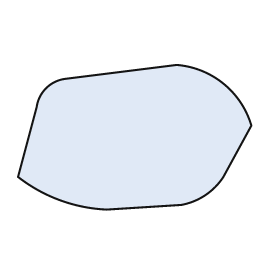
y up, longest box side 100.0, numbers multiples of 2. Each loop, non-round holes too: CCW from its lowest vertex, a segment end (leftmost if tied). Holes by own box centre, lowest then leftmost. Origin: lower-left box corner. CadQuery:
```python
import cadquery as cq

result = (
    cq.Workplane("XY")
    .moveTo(38.0, 0.0)
    .lineTo(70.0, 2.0)
    .threePointArc((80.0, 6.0), (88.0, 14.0))
    .lineTo(100.0, 36.0)
    .threePointArc((88.0, 54.0), (68.0, 62.0))
    .lineTo(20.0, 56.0)
    .threePointArc((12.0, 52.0), (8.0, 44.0))
    .lineTo(0.0, 14.0)
    .threePointArc((18.0, 4.0), (38.0, 0.0))
    .close()
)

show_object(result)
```